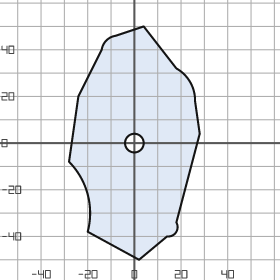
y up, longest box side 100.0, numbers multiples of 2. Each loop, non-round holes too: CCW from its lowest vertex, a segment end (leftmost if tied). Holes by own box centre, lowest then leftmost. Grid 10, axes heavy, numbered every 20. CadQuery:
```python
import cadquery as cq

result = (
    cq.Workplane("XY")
    .moveTo(2.0, -50.0)
    .lineTo(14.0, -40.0)
    .threePointArc((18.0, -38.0), (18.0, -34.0))
    .lineTo(28.0, 4.0)
    .lineTo(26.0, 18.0)
    .threePointArc((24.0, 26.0), (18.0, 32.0))
    .lineTo(4.0, 50.0)
    .lineTo(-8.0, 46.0)
    .threePointArc((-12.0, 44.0), (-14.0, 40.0))
    .lineTo(-24.0, 20.0)
    .lineTo(-28.0, -8.0)
    .threePointArc((-20.0, -22.0), (-20.0, -38.0))
    .close()
    .moveTo(0.0, 0.0)
    .circle(4.0)
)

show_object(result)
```